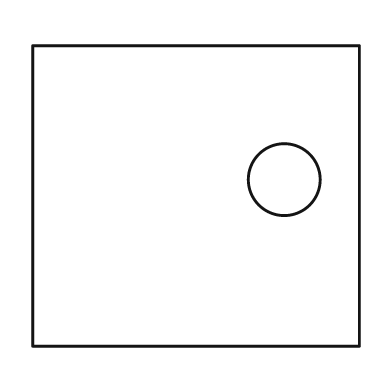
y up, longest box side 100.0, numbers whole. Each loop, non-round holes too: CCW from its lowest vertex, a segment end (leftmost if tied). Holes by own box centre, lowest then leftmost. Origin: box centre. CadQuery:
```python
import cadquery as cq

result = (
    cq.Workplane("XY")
    .moveTo(-50.0, -46.0)
    .lineTo(50.0, -46.0)
    .lineTo(50.0, 46.0)
    .lineTo(-50.0, 46.0)
    .close()
    .moveTo(27.0, 5.0)
    .circle(11.0)
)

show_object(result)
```